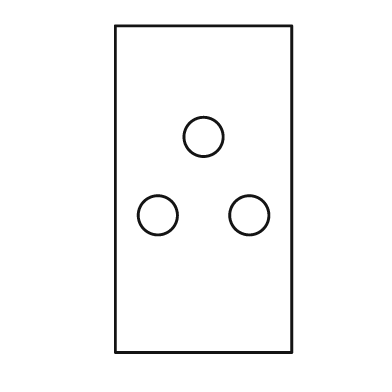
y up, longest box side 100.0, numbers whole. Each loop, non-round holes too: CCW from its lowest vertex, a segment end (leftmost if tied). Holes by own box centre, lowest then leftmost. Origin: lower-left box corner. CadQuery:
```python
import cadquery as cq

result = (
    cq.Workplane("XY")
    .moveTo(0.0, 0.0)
    .lineTo(54.0, 0.0)
    .lineTo(54.0, 100.0)
    .lineTo(0.0, 100.0)
    .close()
    .moveTo(13.0, 42.0)
    .circle(6.0)
    .moveTo(41.0, 42.0)
    .circle(6.0)
    .moveTo(27.0, 66.0)
    .circle(6.0)
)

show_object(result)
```